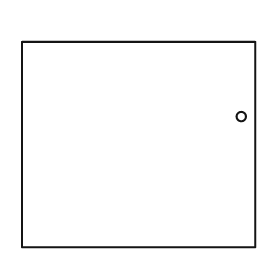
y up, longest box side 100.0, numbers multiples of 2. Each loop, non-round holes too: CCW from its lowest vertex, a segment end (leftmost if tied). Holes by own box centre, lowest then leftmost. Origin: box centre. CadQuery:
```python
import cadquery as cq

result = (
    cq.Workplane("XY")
    .moveTo(-50.0, -44.0)
    .lineTo(50.0, -44.0)
    .lineTo(50.0, 44.0)
    .lineTo(-50.0, 44.0)
    .close()
    .moveTo(44.0, 12.0)
    .circle(2.0)
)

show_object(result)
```